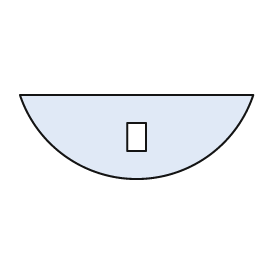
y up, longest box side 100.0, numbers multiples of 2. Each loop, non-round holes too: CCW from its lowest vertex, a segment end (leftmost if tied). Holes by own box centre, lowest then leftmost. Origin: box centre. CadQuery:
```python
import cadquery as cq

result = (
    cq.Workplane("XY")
    .moveTo(-50.0, 18.0)
    .threePointArc((0.0, -18.0), (50.0, 18.0))
    .close()
    .moveTo(-4.0, -6.0)
    .lineTo(4.0, -6.0)
    .lineTo(4.0, 6.0)
    .lineTo(-4.0, 6.0)
    .close()
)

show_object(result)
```